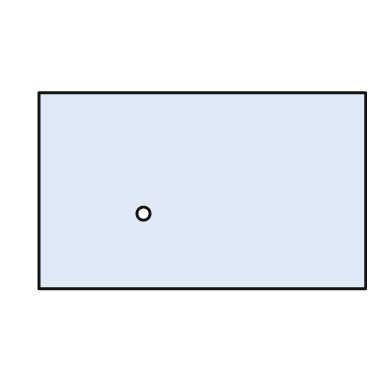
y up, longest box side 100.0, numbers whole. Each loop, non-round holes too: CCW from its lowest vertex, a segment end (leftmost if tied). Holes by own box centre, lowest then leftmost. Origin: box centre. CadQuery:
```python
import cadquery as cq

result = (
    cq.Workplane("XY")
    .moveTo(-50.0, -30.0)
    .lineTo(50.0, -30.0)
    .lineTo(50.0, 30.0)
    .lineTo(-50.0, 30.0)
    .close()
    .moveTo(-18.0, -7.0)
    .circle(2.0)
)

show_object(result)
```